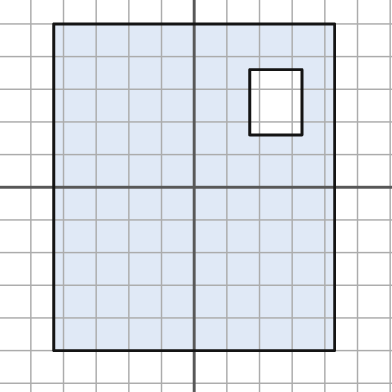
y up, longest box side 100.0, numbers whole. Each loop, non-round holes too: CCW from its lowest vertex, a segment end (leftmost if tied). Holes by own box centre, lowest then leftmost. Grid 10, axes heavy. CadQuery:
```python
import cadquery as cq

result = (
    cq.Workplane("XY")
    .moveTo(-43.0, -50.0)
    .lineTo(43.0, -50.0)
    .lineTo(43.0, 50.0)
    .lineTo(-43.0, 50.0)
    .close()
    .moveTo(17.0, 16.0)
    .lineTo(33.0, 16.0)
    .lineTo(33.0, 36.0)
    .lineTo(17.0, 36.0)
    .close()
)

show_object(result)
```